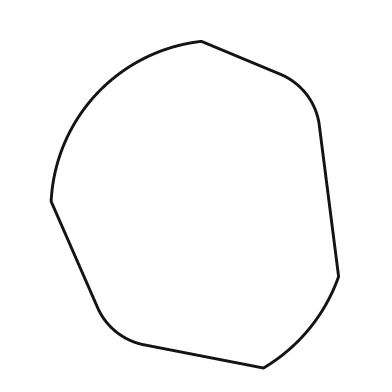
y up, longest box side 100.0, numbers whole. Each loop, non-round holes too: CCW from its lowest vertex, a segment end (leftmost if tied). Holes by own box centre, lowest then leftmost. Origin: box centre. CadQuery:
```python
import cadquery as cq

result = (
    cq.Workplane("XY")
    .moveTo(21.0, -50.0)
    .threePointArc((35.0, -38.0), (44.0, -22.0))
    .lineTo(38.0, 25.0)
    .threePointArc((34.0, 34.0), (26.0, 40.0))
    .lineTo(2.0, 50.0)
    .threePointArc((-30.0, 34.0), (-44.0, 1.0))
    .lineTo(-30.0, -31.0)
    .threePointArc((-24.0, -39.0), (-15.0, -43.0))
    .close()
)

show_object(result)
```